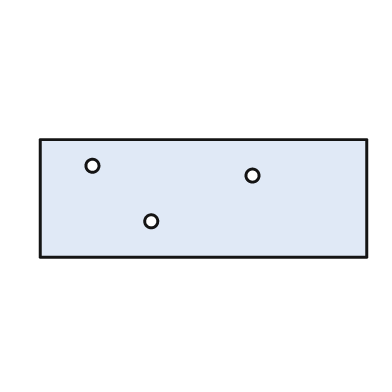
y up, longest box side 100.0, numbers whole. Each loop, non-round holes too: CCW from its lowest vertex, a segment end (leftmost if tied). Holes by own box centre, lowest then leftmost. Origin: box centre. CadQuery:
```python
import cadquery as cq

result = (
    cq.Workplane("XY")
    .moveTo(-50.0, -18.0)
    .lineTo(50.0, -18.0)
    .lineTo(50.0, 18.0)
    .lineTo(-50.0, 18.0)
    .close()
    .moveTo(-16.0, -7.0)
    .circle(2.0)
    .moveTo(15.0, 7.0)
    .circle(2.0)
    .moveTo(-34.0, 10.0)
    .circle(2.0)
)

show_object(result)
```